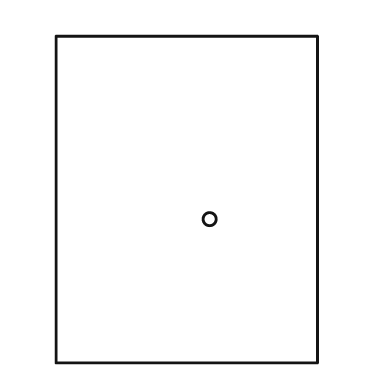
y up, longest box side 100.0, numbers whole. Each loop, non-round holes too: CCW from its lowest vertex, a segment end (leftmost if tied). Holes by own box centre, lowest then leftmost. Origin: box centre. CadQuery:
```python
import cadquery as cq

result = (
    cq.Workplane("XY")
    .moveTo(-40.0, -50.0)
    .lineTo(40.0, -50.0)
    .lineTo(40.0, 50.0)
    .lineTo(-40.0, 50.0)
    .close()
    .moveTo(7.0, -6.0)
    .circle(2.0)
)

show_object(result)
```